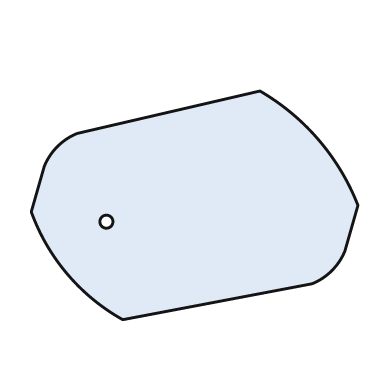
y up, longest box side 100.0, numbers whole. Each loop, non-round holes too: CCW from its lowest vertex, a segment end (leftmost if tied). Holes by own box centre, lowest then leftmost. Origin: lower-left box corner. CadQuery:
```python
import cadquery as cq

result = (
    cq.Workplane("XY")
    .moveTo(28.0, 0.0)
    .lineTo(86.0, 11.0)
    .threePointArc((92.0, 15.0), (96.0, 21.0))
    .lineTo(100.0, 35.0)
    .threePointArc((88.0, 55.0), (70.0, 70.0))
    .lineTo(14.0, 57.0)
    .threePointArc((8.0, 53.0), (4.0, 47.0))
    .lineTo(0.0, 33.0)
    .threePointArc((11.0, 14.0), (28.0, 0.0))
    .close()
    .moveTo(23.0, 30.0)
    .circle(2.0)
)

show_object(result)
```